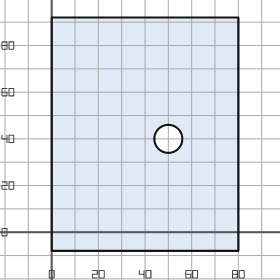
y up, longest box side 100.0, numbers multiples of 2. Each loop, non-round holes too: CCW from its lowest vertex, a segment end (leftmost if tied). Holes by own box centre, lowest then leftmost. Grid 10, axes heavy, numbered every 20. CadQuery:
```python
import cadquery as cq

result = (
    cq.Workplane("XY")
    .moveTo(0.0, -8.0)
    .lineTo(80.0, -8.0)
    .lineTo(80.0, 92.0)
    .lineTo(0.0, 92.0)
    .close()
    .moveTo(50.0, 40.0)
    .circle(6.0)
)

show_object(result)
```